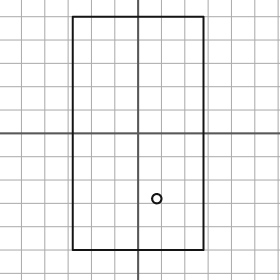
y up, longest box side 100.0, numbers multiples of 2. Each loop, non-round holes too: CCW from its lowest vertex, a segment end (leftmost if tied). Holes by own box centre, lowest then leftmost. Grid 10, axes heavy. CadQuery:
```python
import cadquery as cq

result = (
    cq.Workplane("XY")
    .moveTo(-28.0, -50.0)
    .lineTo(28.0, -50.0)
    .lineTo(28.0, 50.0)
    .lineTo(-28.0, 50.0)
    .close()
    .moveTo(8.0, -28.0)
    .circle(2.0)
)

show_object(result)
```